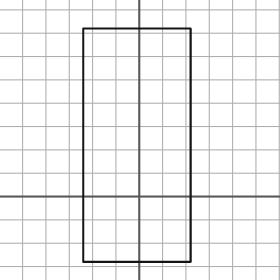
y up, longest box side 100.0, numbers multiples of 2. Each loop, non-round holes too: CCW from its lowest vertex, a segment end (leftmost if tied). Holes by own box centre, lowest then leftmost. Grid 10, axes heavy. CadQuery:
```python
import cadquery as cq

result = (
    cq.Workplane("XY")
    .moveTo(-24.0, -28.0)
    .lineTo(22.0, -28.0)
    .lineTo(22.0, 72.0)
    .lineTo(-24.0, 72.0)
    .close()
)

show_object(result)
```